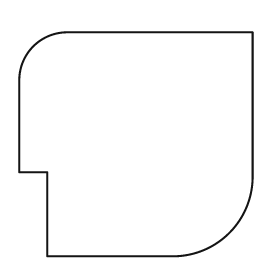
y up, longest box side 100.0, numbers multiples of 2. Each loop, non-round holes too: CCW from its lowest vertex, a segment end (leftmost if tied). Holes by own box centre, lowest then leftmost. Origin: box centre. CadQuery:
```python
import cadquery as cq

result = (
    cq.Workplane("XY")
    .moveTo(-38.0, -48.0)
    .lineTo(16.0, -48.0)
    .threePointArc((40.0, -38.0), (50.0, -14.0))
    .lineTo(50.0, 48.0)
    .lineTo(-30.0, 48.0)
    .threePointArc((-44.0, 42.0), (-50.0, 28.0))
    .lineTo(-50.0, -12.0)
    .lineTo(-38.0, -12.0)
    .close()
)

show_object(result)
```